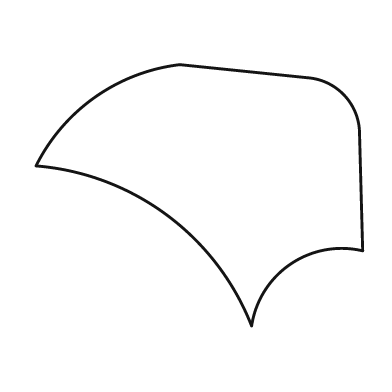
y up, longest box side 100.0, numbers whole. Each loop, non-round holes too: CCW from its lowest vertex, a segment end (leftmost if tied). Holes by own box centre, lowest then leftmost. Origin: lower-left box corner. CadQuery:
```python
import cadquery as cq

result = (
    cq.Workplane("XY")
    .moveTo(66.0, 0.0)
    .threePointArc((78.0, 19.0), (100.0, 23.0))
    .lineTo(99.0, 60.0)
    .threePointArc((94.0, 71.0), (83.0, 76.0))
    .lineTo(44.0, 80.0)
    .threePointArc((18.0, 70.0), (0.0, 49.0))
    .threePointArc((40.0, 34.0), (66.0, 0.0))
    .close()
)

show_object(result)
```